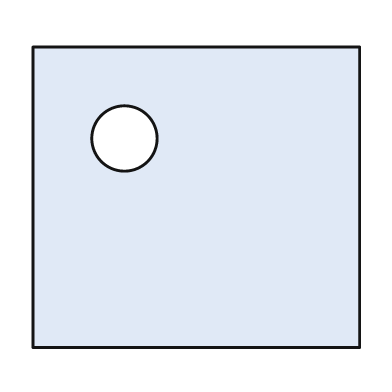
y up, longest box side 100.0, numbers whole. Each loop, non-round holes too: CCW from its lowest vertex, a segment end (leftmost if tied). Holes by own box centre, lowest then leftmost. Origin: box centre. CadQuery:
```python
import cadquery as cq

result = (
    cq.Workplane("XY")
    .moveTo(-50.0, -46.0)
    .lineTo(50.0, -46.0)
    .lineTo(50.0, 46.0)
    .lineTo(-50.0, 46.0)
    .close()
    .moveTo(-22.0, 18.0)
    .circle(10.0)
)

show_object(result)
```